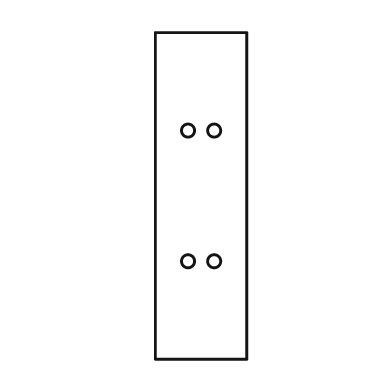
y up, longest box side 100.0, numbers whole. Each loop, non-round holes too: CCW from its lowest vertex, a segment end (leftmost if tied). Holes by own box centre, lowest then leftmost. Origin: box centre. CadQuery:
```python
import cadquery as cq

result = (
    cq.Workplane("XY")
    .moveTo(-14.0, -50.0)
    .lineTo(14.0, -50.0)
    .lineTo(14.0, 50.0)
    .lineTo(-14.0, 50.0)
    .close()
    .moveTo(-4.0, -20.0)
    .circle(2.0)
    .moveTo(4.0, -20.0)
    .circle(2.0)
    .moveTo(-4.0, 20.0)
    .circle(2.0)
    .moveTo(4.0, 20.0)
    .circle(2.0)
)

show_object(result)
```